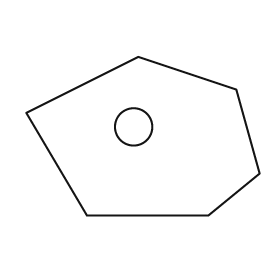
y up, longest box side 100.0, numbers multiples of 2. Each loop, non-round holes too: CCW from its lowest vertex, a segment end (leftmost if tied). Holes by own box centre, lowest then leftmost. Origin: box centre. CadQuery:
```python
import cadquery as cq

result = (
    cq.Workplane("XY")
    .moveTo(-24.0, -34.0)
    .lineTo(28.0, -34.0)
    .lineTo(50.0, -16.0)
    .lineTo(40.0, 20.0)
    .lineTo(-2.0, 34.0)
    .lineTo(-50.0, 10.0)
    .close()
    .moveTo(-4.0, 4.0)
    .circle(8.0)
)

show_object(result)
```